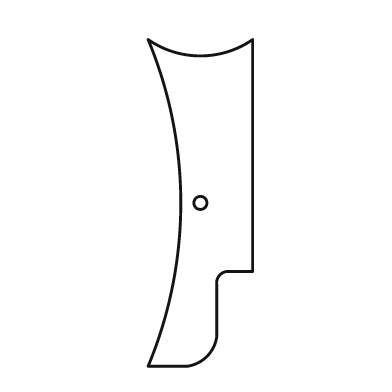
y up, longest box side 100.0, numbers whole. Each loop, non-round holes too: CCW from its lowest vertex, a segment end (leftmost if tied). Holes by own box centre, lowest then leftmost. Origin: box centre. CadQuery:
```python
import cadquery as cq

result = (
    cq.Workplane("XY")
    .moveTo(-16.0, -50.0)
    .lineTo(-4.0, -50.0)
    .threePointArc((2.0, -47.0), (5.0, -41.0))
    .lineTo(5.0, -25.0)
    .threePointArc((6.0, -22.0), (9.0, -21.0))
    .lineTo(16.0, -21.0)
    .lineTo(16.0, 50.0)
    .threePointArc((0.0, 45.0), (-16.0, 50.0))
    .threePointArc((-6.0, 0.0), (-16.0, -50.0))
    .close()
    .moveTo(0.0, 0.0)
    .circle(2.0)
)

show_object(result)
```